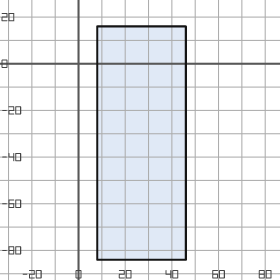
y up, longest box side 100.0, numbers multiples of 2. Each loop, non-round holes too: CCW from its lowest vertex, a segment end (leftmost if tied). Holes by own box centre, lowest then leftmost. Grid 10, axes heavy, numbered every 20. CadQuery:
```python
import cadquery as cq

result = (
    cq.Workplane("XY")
    .moveTo(8.0, -84.0)
    .lineTo(46.0, -84.0)
    .lineTo(46.0, 16.0)
    .lineTo(8.0, 16.0)
    .close()
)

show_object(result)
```